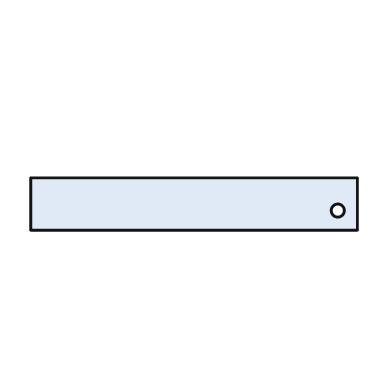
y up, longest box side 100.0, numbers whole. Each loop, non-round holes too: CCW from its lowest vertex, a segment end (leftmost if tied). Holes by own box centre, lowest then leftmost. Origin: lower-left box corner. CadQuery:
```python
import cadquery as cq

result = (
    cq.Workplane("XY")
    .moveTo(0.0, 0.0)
    .lineTo(100.0, 0.0)
    .lineTo(100.0, 16.0)
    .lineTo(0.0, 16.0)
    .close()
    .moveTo(94.0, 6.0)
    .circle(2.0)
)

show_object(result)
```